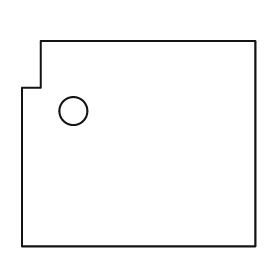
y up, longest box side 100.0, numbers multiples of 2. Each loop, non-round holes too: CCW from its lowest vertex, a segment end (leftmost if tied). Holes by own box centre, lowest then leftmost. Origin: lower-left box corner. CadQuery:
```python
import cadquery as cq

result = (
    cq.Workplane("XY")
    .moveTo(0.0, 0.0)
    .lineTo(100.0, 0.0)
    .lineTo(100.0, 88.0)
    .lineTo(8.0, 88.0)
    .lineTo(8.0, 68.0)
    .lineTo(0.0, 68.0)
    .close()
    .moveTo(22.0, 58.0)
    .circle(6.0)
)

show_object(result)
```